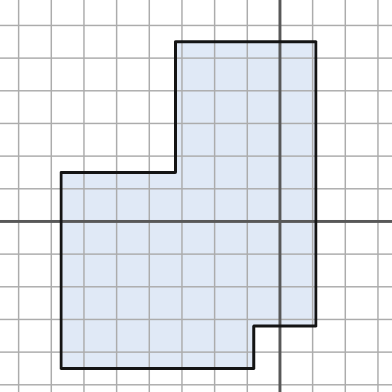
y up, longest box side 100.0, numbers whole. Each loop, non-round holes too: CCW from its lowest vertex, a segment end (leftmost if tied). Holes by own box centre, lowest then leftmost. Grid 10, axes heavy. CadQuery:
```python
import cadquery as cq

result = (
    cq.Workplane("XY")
    .moveTo(-67.0, -45.0)
    .lineTo(-8.0, -45.0)
    .lineTo(-8.0, -32.0)
    .lineTo(11.0, -32.0)
    .lineTo(11.0, 55.0)
    .lineTo(-32.0, 55.0)
    .lineTo(-32.0, 15.0)
    .lineTo(-67.0, 15.0)
    .close()
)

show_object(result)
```